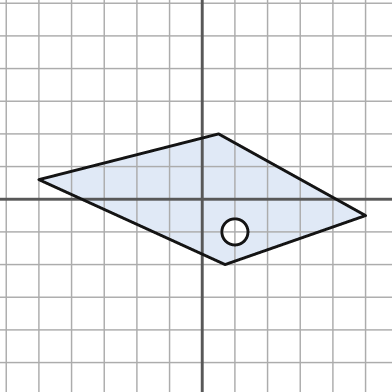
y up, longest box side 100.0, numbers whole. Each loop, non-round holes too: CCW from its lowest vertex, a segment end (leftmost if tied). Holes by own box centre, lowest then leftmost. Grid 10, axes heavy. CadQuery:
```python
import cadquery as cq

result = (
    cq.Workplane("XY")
    .moveTo(7.0, -20.0)
    .lineTo(50.0, -5.0)
    .lineTo(5.0, 20.0)
    .lineTo(-50.0, 6.0)
    .close()
    .moveTo(10.0, -10.0)
    .circle(4.0)
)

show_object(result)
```